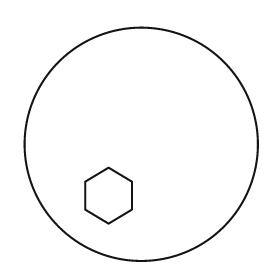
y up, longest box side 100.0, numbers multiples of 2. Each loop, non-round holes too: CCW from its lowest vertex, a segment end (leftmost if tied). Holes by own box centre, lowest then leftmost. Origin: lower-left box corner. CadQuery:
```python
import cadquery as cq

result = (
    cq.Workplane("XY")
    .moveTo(50.0, 50.0)
    .circle(50.0)
    .moveTo(36.0, 16.0)
    .lineTo(46.0, 22.0)
    .lineTo(46.0, 34.0)
    .lineTo(36.0, 40.0)
    .lineTo(26.0, 34.0)
    .lineTo(26.0, 22.0)
    .close()
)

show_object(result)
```